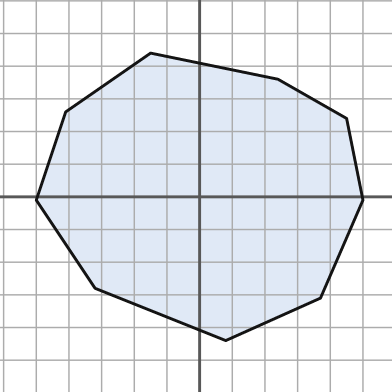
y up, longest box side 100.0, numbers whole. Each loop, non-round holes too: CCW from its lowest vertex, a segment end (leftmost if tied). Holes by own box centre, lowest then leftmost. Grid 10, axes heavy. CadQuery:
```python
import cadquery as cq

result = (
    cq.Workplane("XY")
    .moveTo(8.0, -44.0)
    .lineTo(37.0, -31.0)
    .lineTo(50.0, -1.0)
    .lineTo(45.0, 24.0)
    .lineTo(24.0, 36.0)
    .lineTo(-15.0, 44.0)
    .lineTo(-41.0, 26.0)
    .lineTo(-50.0, -1.0)
    .lineTo(-32.0, -28.0)
    .close()
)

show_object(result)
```